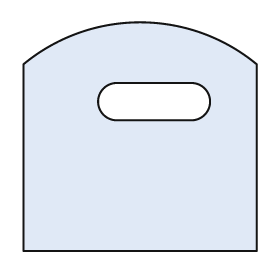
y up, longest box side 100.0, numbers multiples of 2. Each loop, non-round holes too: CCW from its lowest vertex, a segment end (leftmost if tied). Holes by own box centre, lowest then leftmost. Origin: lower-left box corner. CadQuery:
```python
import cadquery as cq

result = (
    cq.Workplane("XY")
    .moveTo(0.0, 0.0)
    .lineTo(100.0, 0.0)
    .lineTo(100.0, 80.0)
    .threePointArc((50.0, 98.0), (0.0, 80.0))
    .close()
    .moveTo(40.0, 56.0)
    .lineTo(72.0, 56.0)
    .threePointArc((80.0, 64.0), (72.0, 72.0))
    .lineTo(40.0, 72.0)
    .threePointArc((32.0, 64.0), (40.0, 56.0))
    .close()
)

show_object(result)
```